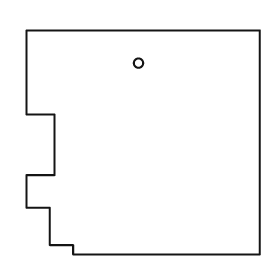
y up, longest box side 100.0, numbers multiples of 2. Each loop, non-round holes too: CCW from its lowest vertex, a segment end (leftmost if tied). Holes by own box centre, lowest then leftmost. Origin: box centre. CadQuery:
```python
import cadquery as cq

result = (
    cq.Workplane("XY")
    .moveTo(-30.0, -48.0)
    .lineTo(50.0, -48.0)
    .lineTo(50.0, 48.0)
    .lineTo(-50.0, 48.0)
    .lineTo(-50.0, 12.0)
    .lineTo(-38.0, 12.0)
    .lineTo(-38.0, -14.0)
    .lineTo(-50.0, -14.0)
    .lineTo(-50.0, -28.0)
    .lineTo(-40.0, -28.0)
    .lineTo(-40.0, -44.0)
    .lineTo(-30.0, -44.0)
    .close()
    .moveTo(-2.0, 34.0)
    .circle(2.0)
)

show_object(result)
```